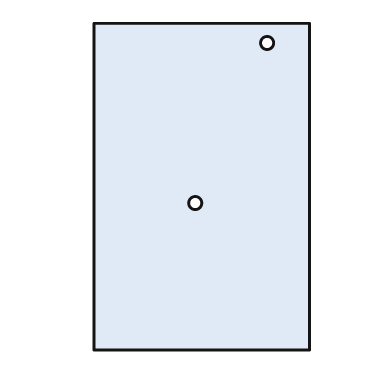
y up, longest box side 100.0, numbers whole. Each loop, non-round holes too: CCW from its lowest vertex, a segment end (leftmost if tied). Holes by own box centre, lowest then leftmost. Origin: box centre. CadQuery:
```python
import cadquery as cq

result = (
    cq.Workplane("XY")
    .moveTo(-33.0, -50.0)
    .lineTo(33.0, -50.0)
    .lineTo(33.0, 50.0)
    .lineTo(-33.0, 50.0)
    .close()
    .moveTo(-2.0, -5.0)
    .circle(2.0)
    .moveTo(20.0, 44.0)
    .circle(2.0)
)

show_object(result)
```